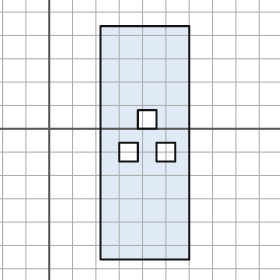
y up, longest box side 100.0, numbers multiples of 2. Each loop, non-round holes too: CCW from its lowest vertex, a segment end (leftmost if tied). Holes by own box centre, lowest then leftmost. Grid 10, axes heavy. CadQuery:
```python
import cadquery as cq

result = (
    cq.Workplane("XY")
    .moveTo(22.0, -56.0)
    .lineTo(60.0, -56.0)
    .lineTo(60.0, 44.0)
    .lineTo(22.0, 44.0)
    .close()
    .moveTo(30.0, -14.0)
    .lineTo(38.0, -14.0)
    .lineTo(38.0, -6.0)
    .lineTo(30.0, -6.0)
    .close()
    .moveTo(46.0, -14.0)
    .lineTo(54.0, -14.0)
    .lineTo(54.0, -6.0)
    .lineTo(46.0, -6.0)
    .close()
    .moveTo(38.0, 0.0)
    .lineTo(46.0, 0.0)
    .lineTo(46.0, 8.0)
    .lineTo(38.0, 8.0)
    .close()
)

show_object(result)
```